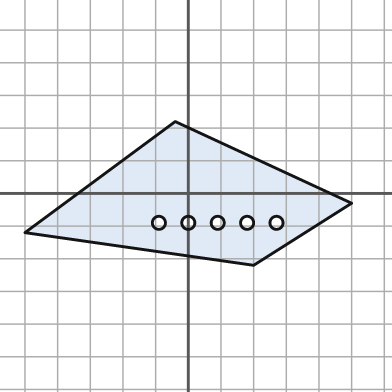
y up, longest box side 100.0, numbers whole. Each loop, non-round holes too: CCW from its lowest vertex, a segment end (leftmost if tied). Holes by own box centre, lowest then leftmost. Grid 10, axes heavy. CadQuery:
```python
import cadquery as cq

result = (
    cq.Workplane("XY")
    .moveTo(20.0, -22.0)
    .lineTo(50.0, -3.0)
    .lineTo(-4.0, 22.0)
    .lineTo(-50.0, -12.0)
    .close()
    .moveTo(-9.0, -9.0)
    .circle(2.0)
    .moveTo(0.0, -9.0)
    .circle(2.0)
    .moveTo(9.0, -9.0)
    .circle(2.0)
    .moveTo(18.0, -9.0)
    .circle(2.0)
    .moveTo(27.0, -9.0)
    .circle(2.0)
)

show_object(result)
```